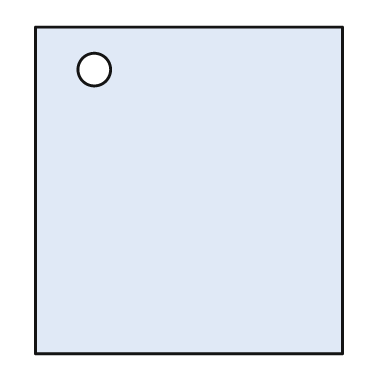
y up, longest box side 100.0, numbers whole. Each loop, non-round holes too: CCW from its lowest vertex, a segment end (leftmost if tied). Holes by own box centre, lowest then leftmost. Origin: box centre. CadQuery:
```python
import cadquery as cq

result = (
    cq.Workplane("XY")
    .moveTo(-47.0, -50.0)
    .lineTo(47.0, -50.0)
    .lineTo(47.0, 50.0)
    .lineTo(-47.0, 50.0)
    .close()
    .moveTo(-29.0, 37.0)
    .circle(5.0)
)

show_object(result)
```